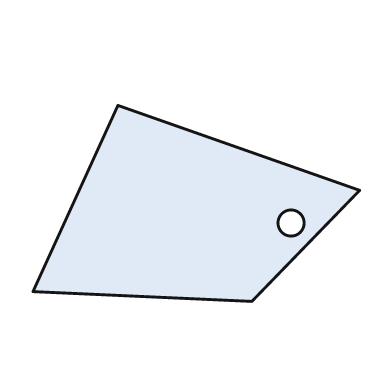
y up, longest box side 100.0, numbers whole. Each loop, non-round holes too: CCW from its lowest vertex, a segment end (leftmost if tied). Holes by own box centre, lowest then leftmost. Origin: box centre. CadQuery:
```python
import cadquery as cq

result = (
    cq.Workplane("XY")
    .moveTo(17.0, -30.0)
    .lineTo(50.0, 4.0)
    .lineTo(-24.0, 30.0)
    .lineTo(-50.0, -27.0)
    .close()
    .moveTo(29.0, -6.0)
    .circle(4.0)
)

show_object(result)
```